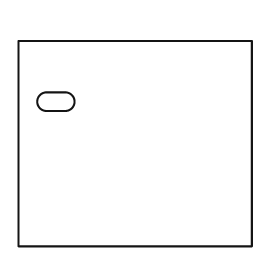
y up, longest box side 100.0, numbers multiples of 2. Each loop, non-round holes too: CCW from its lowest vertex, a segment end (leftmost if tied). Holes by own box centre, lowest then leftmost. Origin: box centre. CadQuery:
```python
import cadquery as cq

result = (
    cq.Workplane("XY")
    .moveTo(-50.0, -44.0)
    .lineTo(50.0, -44.0)
    .lineTo(50.0, 44.0)
    .lineTo(-50.0, 44.0)
    .close()
    .moveTo(-38.0, 14.0)
    .lineTo(-30.0, 14.0)
    .threePointArc((-26.0, 18.0), (-30.0, 22.0))
    .lineTo(-38.0, 22.0)
    .threePointArc((-42.0, 18.0), (-38.0, 14.0))
    .close()
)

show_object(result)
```